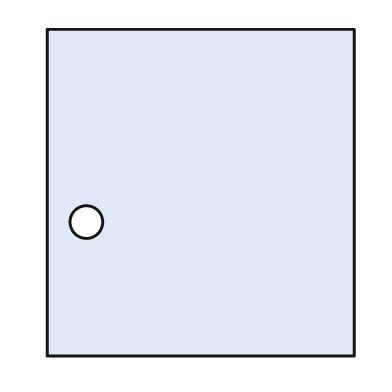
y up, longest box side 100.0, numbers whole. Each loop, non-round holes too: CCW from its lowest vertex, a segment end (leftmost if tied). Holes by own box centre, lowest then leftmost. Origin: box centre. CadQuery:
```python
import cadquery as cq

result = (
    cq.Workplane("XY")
    .moveTo(-47.0, -50.0)
    .lineTo(47.0, -50.0)
    .lineTo(47.0, 50.0)
    .lineTo(-47.0, 50.0)
    .close()
    .moveTo(-35.0, -9.0)
    .circle(5.0)
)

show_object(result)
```